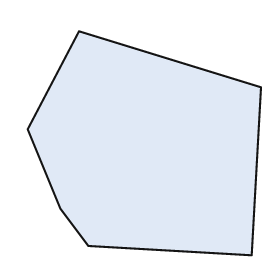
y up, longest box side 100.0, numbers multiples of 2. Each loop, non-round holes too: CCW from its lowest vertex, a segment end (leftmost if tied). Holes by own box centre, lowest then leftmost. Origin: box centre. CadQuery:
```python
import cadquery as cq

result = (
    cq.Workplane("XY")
    .moveTo(46.0, -48.0)
    .lineTo(50.0, 24.0)
    .lineTo(-28.0, 48.0)
    .lineTo(-50.0, 6.0)
    .lineTo(-36.0, -28.0)
    .lineTo(-24.0, -44.0)
    .close()
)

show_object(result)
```